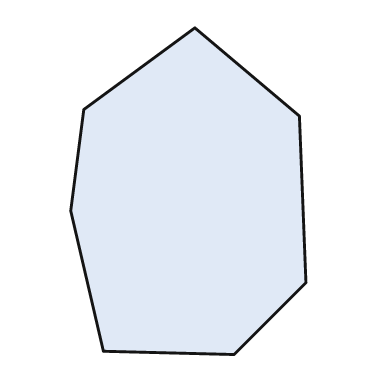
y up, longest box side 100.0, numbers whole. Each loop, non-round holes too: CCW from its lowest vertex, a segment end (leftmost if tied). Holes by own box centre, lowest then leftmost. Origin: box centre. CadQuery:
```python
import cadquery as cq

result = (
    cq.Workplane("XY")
    .moveTo(14.0, -50.0)
    .lineTo(36.0, -28.0)
    .lineTo(34.0, 23.0)
    .lineTo(2.0, 50.0)
    .lineTo(-32.0, 25.0)
    .lineTo(-36.0, -6.0)
    .lineTo(-26.0, -49.0)
    .close()
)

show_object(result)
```